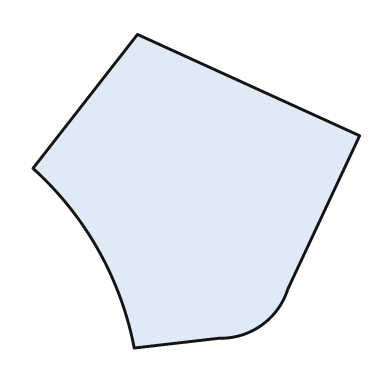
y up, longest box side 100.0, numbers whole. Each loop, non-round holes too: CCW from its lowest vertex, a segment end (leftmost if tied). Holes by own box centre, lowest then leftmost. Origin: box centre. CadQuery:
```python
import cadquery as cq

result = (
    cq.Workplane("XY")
    .moveTo(-19.0, -48.0)
    .lineTo(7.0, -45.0)
    .threePointArc((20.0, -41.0), (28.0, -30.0))
    .lineTo(50.0, 17.0)
    .lineTo(-18.0, 48.0)
    .lineTo(-50.0, 7.0)
    .threePointArc((-30.0, -18.0), (-19.0, -48.0))
    .close()
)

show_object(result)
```